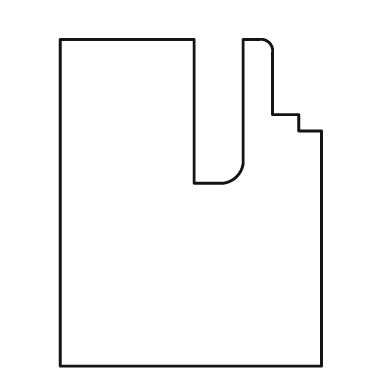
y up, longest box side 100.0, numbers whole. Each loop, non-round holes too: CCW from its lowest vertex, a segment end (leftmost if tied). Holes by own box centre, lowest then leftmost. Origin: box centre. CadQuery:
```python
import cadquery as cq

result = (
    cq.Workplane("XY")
    .moveTo(-40.0, -50.0)
    .lineTo(40.0, -50.0)
    .lineTo(40.0, 22.0)
    .lineTo(33.0, 22.0)
    .lineTo(33.0, 27.0)
    .lineTo(25.0, 27.0)
    .lineTo(25.0, 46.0)
    .threePointArc((24.0, 49.0), (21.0, 50.0))
    .lineTo(16.0, 50.0)
    .lineTo(16.0, 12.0)
    .threePointArc((14.0, 8.0), (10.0, 6.0))
    .lineTo(1.0, 6.0)
    .lineTo(1.0, 50.0)
    .lineTo(-40.0, 50.0)
    .close()
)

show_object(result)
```